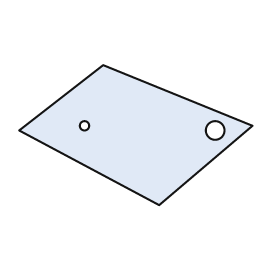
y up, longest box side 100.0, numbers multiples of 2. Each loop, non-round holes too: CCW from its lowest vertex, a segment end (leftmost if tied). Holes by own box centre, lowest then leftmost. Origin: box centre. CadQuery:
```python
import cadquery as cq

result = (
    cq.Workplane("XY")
    .moveTo(10.0, -30.0)
    .lineTo(50.0, 4.0)
    .lineTo(-14.0, 30.0)
    .lineTo(-50.0, 2.0)
    .close()
    .moveTo(34.0, 2.0)
    .circle(4.0)
    .moveTo(-22.0, 4.0)
    .circle(2.0)
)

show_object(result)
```